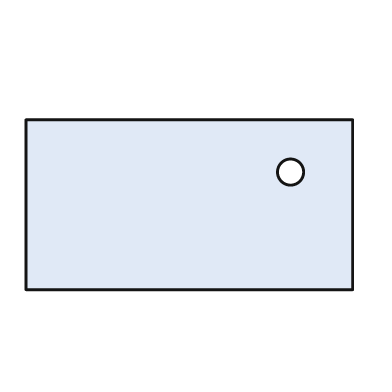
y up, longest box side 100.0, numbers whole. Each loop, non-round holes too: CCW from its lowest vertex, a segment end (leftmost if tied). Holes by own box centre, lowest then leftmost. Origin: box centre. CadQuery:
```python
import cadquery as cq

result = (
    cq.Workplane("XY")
    .moveTo(-50.0, -26.0)
    .lineTo(50.0, -26.0)
    .lineTo(50.0, 26.0)
    .lineTo(-50.0, 26.0)
    .close()
    .moveTo(31.0, 10.0)
    .circle(4.0)
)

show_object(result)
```